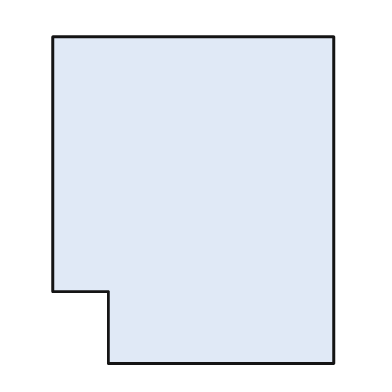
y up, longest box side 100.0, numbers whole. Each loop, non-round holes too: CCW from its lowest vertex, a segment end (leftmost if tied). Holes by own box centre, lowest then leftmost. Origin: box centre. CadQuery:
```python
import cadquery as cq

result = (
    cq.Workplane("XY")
    .moveTo(-26.0, -50.0)
    .lineTo(43.0, -50.0)
    .lineTo(43.0, 50.0)
    .lineTo(-43.0, 50.0)
    .lineTo(-43.0, -28.0)
    .lineTo(-26.0, -28.0)
    .close()
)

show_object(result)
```